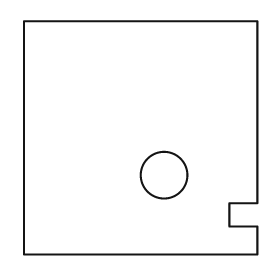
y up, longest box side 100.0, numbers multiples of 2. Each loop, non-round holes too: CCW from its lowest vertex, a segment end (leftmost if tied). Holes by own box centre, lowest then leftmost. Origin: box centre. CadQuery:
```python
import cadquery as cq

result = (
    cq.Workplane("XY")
    .moveTo(-50.0, -50.0)
    .lineTo(50.0, -50.0)
    .lineTo(50.0, -38.0)
    .lineTo(38.0, -38.0)
    .lineTo(38.0, -28.0)
    .lineTo(50.0, -28.0)
    .lineTo(50.0, 50.0)
    .lineTo(-50.0, 50.0)
    .close()
    .moveTo(10.0, -16.0)
    .circle(10.0)
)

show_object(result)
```